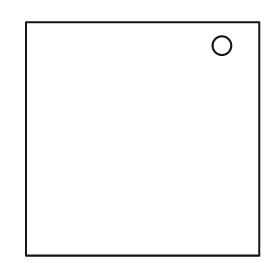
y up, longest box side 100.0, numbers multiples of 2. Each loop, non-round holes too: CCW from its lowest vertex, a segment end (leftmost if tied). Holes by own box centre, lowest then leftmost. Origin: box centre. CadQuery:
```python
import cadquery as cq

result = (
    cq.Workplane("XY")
    .moveTo(-50.0, -50.0)
    .lineTo(50.0, -50.0)
    .lineTo(50.0, 50.0)
    .lineTo(-50.0, 50.0)
    .close()
    .moveTo(34.0, 40.0)
    .circle(4.0)
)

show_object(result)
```